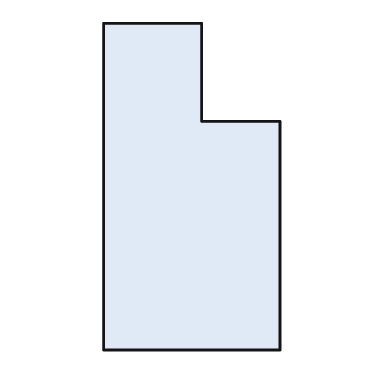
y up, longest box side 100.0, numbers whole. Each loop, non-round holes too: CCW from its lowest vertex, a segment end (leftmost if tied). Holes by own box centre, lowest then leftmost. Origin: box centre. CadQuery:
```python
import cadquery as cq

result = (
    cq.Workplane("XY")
    .moveTo(-27.0, -50.0)
    .lineTo(27.0, -50.0)
    .lineTo(27.0, 20.0)
    .lineTo(3.0, 20.0)
    .lineTo(3.0, 50.0)
    .lineTo(-27.0, 50.0)
    .close()
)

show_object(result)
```